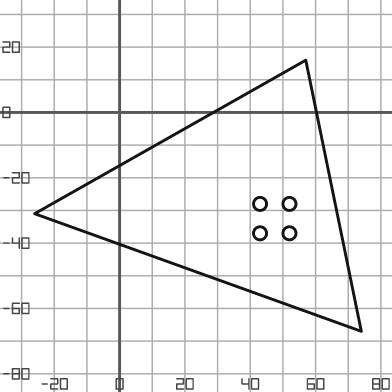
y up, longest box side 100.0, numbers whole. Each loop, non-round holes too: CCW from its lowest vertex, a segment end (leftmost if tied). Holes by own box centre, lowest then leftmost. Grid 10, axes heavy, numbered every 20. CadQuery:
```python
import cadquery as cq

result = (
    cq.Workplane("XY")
    .moveTo(74.0, -67.0)
    .lineTo(57.0, 16.0)
    .lineTo(-26.0, -31.0)
    .close()
    .moveTo(43.0, -37.0)
    .circle(2.0)
    .moveTo(52.0, -37.0)
    .circle(2.0)
    .moveTo(43.0, -28.0)
    .circle(2.0)
    .moveTo(52.0, -28.0)
    .circle(2.0)
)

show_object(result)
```